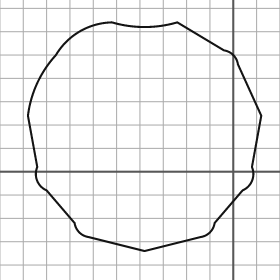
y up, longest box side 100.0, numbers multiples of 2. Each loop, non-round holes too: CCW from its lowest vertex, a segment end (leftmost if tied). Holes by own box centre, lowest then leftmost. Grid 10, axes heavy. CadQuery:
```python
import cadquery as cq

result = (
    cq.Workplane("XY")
    .moveTo(-38.0, -34.0)
    .lineTo(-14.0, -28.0)
    .threePointArc((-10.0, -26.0), (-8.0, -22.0))
    .lineTo(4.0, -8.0)
    .threePointArc((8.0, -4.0), (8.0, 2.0))
    .lineTo(12.0, 24.0)
    .lineTo(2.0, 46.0)
    .threePointArc((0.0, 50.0), (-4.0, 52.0))
    .lineTo(-24.0, 64.0)
    .threePointArc((-38.0, 62.0), (-52.0, 64.0))
    .threePointArc((-66.0, 60.0), (-76.0, 50.0))
    .threePointArc((-84.0, 38.0), (-88.0, 24.0))
    .lineTo(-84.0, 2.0)
    .threePointArc((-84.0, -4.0), (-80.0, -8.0))
    .lineTo(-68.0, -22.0)
    .threePointArc((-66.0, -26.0), (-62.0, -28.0))
    .close()
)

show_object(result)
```